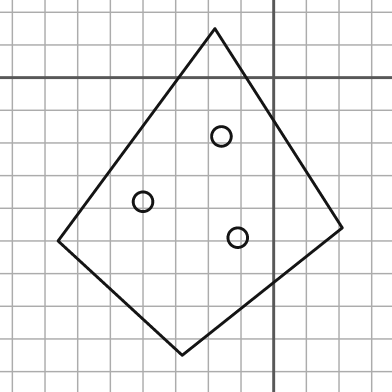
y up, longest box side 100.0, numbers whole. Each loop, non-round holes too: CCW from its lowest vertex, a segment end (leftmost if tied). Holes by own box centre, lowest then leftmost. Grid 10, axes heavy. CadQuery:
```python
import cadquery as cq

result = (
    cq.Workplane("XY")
    .moveTo(-28.0, -85.0)
    .lineTo(21.0, -46.0)
    .lineTo(-18.0, 15.0)
    .lineTo(-66.0, -50.0)
    .close()
    .moveTo(-11.0, -49.0)
    .circle(3.0)
    .moveTo(-40.0, -38.0)
    .circle(3.0)
    .moveTo(-16.0, -18.0)
    .circle(3.0)
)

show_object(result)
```